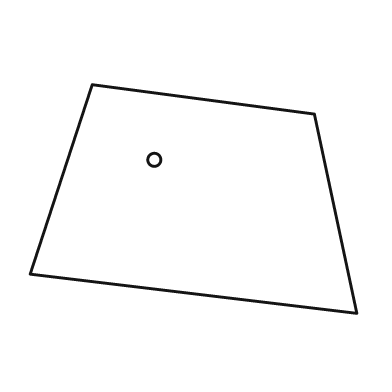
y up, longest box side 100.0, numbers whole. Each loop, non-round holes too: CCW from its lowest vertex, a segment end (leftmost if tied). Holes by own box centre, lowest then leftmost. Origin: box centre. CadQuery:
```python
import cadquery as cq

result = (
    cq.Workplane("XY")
    .moveTo(50.0, -35.0)
    .lineTo(37.0, 26.0)
    .lineTo(-31.0, 35.0)
    .lineTo(-50.0, -23.0)
    .close()
    .moveTo(-12.0, 12.0)
    .circle(2.0)
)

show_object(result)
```